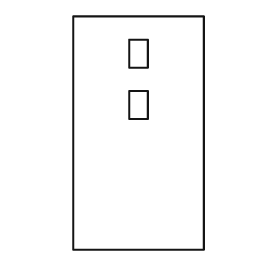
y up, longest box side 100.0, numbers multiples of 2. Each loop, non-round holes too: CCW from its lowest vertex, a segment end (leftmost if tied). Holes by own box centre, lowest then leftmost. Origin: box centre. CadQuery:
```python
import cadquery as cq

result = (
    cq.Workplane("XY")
    .moveTo(-28.0, -50.0)
    .lineTo(28.0, -50.0)
    .lineTo(28.0, 50.0)
    .lineTo(-28.0, 50.0)
    .close()
    .moveTo(-4.0, 6.0)
    .lineTo(4.0, 6.0)
    .lineTo(4.0, 18.0)
    .lineTo(-4.0, 18.0)
    .close()
    .moveTo(-4.0, 28.0)
    .lineTo(4.0, 28.0)
    .lineTo(4.0, 40.0)
    .lineTo(-4.0, 40.0)
    .close()
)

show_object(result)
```